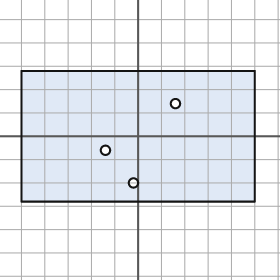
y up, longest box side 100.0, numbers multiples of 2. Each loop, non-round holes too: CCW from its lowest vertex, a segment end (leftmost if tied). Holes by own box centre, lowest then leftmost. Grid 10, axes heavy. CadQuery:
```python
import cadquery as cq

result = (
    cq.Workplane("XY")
    .moveTo(-50.0, -28.0)
    .lineTo(50.0, -28.0)
    .lineTo(50.0, 28.0)
    .lineTo(-50.0, 28.0)
    .close()
    .moveTo(-2.0, -20.0)
    .circle(2.0)
    .moveTo(-14.0, -6.0)
    .circle(2.0)
    .moveTo(16.0, 14.0)
    .circle(2.0)
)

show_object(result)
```